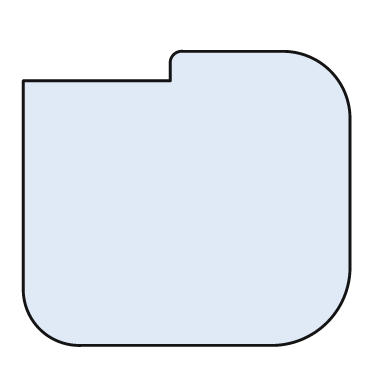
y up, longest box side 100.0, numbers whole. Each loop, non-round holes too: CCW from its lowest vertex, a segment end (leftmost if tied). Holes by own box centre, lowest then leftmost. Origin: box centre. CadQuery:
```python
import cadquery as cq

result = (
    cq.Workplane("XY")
    .moveTo(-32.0, -45.0)
    .lineTo(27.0, -45.0)
    .threePointArc((43.0, -38.0), (50.0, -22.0))
    .lineTo(50.0, 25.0)
    .threePointArc((44.0, 39.0), (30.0, 45.0))
    .lineTo(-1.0, 45.0)
    .threePointArc((-4.0, 44.0), (-5.0, 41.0))
    .lineTo(-5.0, 36.0)
    .lineTo(-50.0, 36.0)
    .lineTo(-50.0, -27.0)
    .threePointArc((-45.0, -40.0), (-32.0, -45.0))
    .close()
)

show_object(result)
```